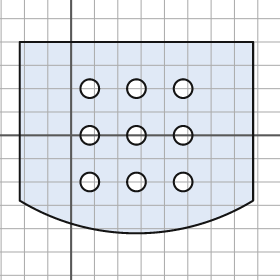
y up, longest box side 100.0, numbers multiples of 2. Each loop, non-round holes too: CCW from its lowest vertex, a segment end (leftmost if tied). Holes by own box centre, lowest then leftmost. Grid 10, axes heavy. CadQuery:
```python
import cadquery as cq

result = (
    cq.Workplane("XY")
    .moveTo(-22.0, -28.0)
    .threePointArc((28.0, -42.0), (78.0, -28.0))
    .lineTo(78.0, 40.0)
    .lineTo(-22.0, 40.0)
    .close()
    .moveTo(8.0, -20.0)
    .circle(4.0)
    .moveTo(28.0, -20.0)
    .circle(4.0)
    .moveTo(48.0, -20.0)
    .circle(4.0)
    .moveTo(8.0, 0.0)
    .circle(4.0)
    .moveTo(28.0, 0.0)
    .circle(4.0)
    .moveTo(48.0, 0.0)
    .circle(4.0)
    .moveTo(8.0, 20.0)
    .circle(4.0)
    .moveTo(28.0, 20.0)
    .circle(4.0)
    .moveTo(48.0, 20.0)
    .circle(4.0)
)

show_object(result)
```